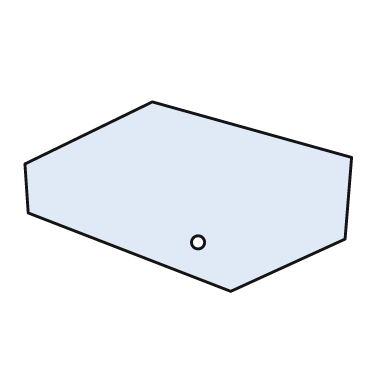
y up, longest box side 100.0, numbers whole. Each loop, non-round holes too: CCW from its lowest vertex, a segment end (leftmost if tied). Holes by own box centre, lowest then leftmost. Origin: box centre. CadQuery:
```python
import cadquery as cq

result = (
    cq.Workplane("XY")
    .moveTo(13.0, -29.0)
    .lineTo(48.0, -13.0)
    .lineTo(50.0, 12.0)
    .lineTo(-11.0, 29.0)
    .lineTo(-50.0, 10.0)
    .lineTo(-49.0, -5.0)
    .close()
    .moveTo(3.0, -14.0)
    .circle(2.0)
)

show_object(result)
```